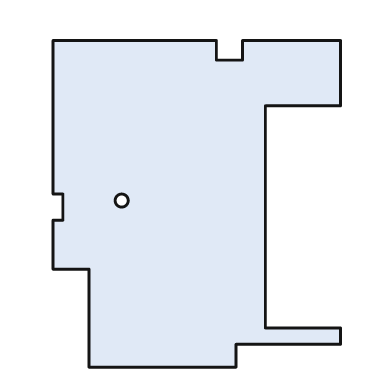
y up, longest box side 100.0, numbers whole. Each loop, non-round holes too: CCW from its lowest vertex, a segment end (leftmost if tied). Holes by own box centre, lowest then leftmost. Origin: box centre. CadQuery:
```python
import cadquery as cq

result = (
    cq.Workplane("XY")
    .moveTo(-33.0, -50.0)
    .lineTo(12.0, -50.0)
    .lineTo(12.0, -43.0)
    .lineTo(44.0, -43.0)
    .lineTo(44.0, -38.0)
    .lineTo(21.0, -38.0)
    .lineTo(21.0, 30.0)
    .lineTo(44.0, 30.0)
    .lineTo(44.0, 50.0)
    .lineTo(14.0, 50.0)
    .lineTo(14.0, 44.0)
    .lineTo(6.0, 44.0)
    .lineTo(6.0, 50.0)
    .lineTo(-44.0, 50.0)
    .lineTo(-44.0, 3.0)
    .lineTo(-41.0, 3.0)
    .lineTo(-41.0, -5.0)
    .lineTo(-44.0, -5.0)
    .lineTo(-44.0, -20.0)
    .lineTo(-33.0, -20.0)
    .close()
    .moveTo(-23.0, 1.0)
    .circle(2.0)
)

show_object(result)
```